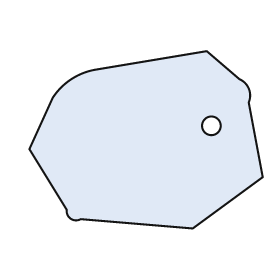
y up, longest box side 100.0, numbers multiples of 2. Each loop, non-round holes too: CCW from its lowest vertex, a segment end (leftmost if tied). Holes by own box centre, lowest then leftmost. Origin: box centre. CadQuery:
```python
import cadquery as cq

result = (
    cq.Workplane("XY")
    .moveTo(20.0, -38.0)
    .lineTo(50.0, -16.0)
    .lineTo(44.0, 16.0)
    .threePointArc((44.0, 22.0), (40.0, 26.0))
    .lineTo(26.0, 38.0)
    .lineTo(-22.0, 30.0)
    .threePointArc((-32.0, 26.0), (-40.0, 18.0))
    .lineTo(-50.0, -4.0)
    .lineTo(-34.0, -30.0)
    .threePointArc((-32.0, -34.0), (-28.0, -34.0))
    .close()
    .moveTo(28.0, 6.0)
    .circle(4.0)
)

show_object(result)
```